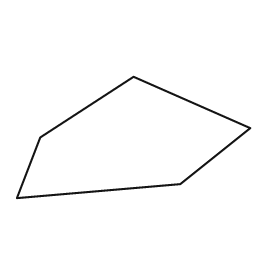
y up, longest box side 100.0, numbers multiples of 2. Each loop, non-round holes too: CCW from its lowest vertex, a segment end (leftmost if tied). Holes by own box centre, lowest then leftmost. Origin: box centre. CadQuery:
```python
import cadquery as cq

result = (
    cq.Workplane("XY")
    .moveTo(-50.0, -26.0)
    .lineTo(20.0, -20.0)
    .lineTo(50.0, 4.0)
    .lineTo(0.0, 26.0)
    .lineTo(-40.0, 0.0)
    .close()
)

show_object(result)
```